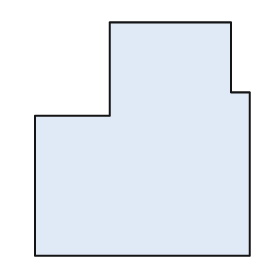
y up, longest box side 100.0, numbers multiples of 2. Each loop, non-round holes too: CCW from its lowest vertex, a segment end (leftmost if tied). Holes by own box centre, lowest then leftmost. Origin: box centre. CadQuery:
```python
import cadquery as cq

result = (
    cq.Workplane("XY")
    .moveTo(-46.0, -50.0)
    .lineTo(46.0, -50.0)
    .lineTo(46.0, 20.0)
    .lineTo(38.0, 20.0)
    .lineTo(38.0, 50.0)
    .lineTo(-14.0, 50.0)
    .lineTo(-14.0, 10.0)
    .lineTo(-46.0, 10.0)
    .close()
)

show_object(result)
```